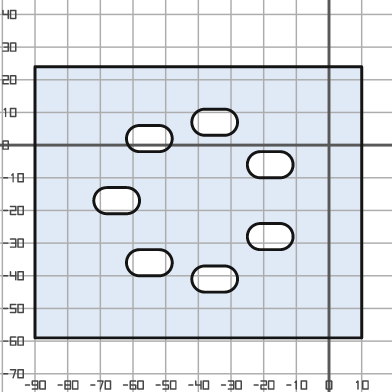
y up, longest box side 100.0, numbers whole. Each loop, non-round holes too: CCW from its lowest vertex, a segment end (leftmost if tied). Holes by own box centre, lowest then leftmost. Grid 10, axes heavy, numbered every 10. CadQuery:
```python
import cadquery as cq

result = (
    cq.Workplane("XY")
    .moveTo(-90.0, -59.0)
    .lineTo(10.0, -59.0)
    .lineTo(10.0, 24.0)
    .lineTo(-90.0, 24.0)
    .close()
    .moveTo(-38.0, -45.0)
    .lineTo(-32.0, -45.0)
    .threePointArc((-28.0, -41.0), (-32.0, -37.0))
    .lineTo(-38.0, -37.0)
    .threePointArc((-42.0, -41.0), (-38.0, -45.0))
    .close()
    .moveTo(-58.0, -40.0)
    .lineTo(-52.0, -40.0)
    .threePointArc((-48.0, -36.0), (-52.0, -32.0))
    .lineTo(-58.0, -32.0)
    .threePointArc((-62.0, -36.0), (-58.0, -40.0))
    .close()
    .moveTo(-21.0, -32.0)
    .lineTo(-15.0, -32.0)
    .threePointArc((-11.0, -28.0), (-15.0, -24.0))
    .lineTo(-21.0, -24.0)
    .threePointArc((-25.0, -28.0), (-21.0, -32.0))
    .close()
    .moveTo(-68.0, -21.0)
    .lineTo(-62.0, -21.0)
    .threePointArc((-58.0, -17.0), (-62.0, -13.0))
    .lineTo(-68.0, -13.0)
    .threePointArc((-72.0, -17.0), (-68.0, -21.0))
    .close()
    .moveTo(-21.0, -10.0)
    .lineTo(-15.0, -10.0)
    .threePointArc((-11.0, -6.0), (-15.0, -2.0))
    .lineTo(-21.0, -2.0)
    .threePointArc((-25.0, -6.0), (-21.0, -10.0))
    .close()
    .moveTo(-58.0, -2.0)
    .lineTo(-52.0, -2.0)
    .threePointArc((-48.0, 2.0), (-52.0, 6.0))
    .lineTo(-58.0, 6.0)
    .threePointArc((-62.0, 2.0), (-58.0, -2.0))
    .close()
    .moveTo(-38.0, 3.0)
    .lineTo(-32.0, 3.0)
    .threePointArc((-28.0, 7.0), (-32.0, 11.0))
    .lineTo(-38.0, 11.0)
    .threePointArc((-42.0, 7.0), (-38.0, 3.0))
    .close()
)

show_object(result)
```